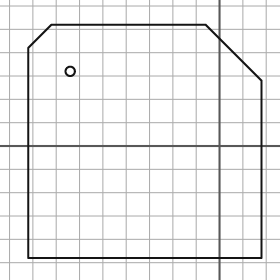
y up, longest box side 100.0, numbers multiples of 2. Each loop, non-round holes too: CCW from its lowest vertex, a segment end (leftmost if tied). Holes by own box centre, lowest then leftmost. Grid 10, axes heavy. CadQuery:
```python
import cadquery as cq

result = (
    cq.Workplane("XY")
    .moveTo(-82.0, -48.0)
    .lineTo(18.0, -48.0)
    .lineTo(18.0, 28.0)
    .lineTo(-6.0, 52.0)
    .lineTo(-72.0, 52.0)
    .lineTo(-82.0, 42.0)
    .close()
    .moveTo(-64.0, 32.0)
    .circle(2.0)
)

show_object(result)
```